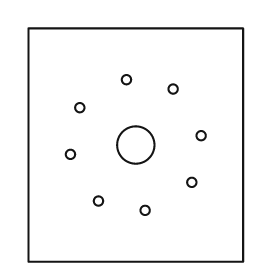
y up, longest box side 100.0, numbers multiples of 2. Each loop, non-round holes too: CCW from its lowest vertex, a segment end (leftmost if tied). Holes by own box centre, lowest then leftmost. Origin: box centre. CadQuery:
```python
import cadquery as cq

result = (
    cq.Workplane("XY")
    .moveTo(-46.0, -50.0)
    .lineTo(46.0, -50.0)
    .lineTo(46.0, 50.0)
    .lineTo(-46.0, 50.0)
    .close()
    .moveTo(4.0, -28.0)
    .circle(2.0)
    .moveTo(-16.0, -24.0)
    .circle(2.0)
    .moveTo(24.0, -16.0)
    .circle(2.0)
    .moveTo(-28.0, -4.0)
    .circle(2.0)
    .moveTo(0.0, 0.0)
    .circle(8.0)
    .moveTo(28.0, 4.0)
    .circle(2.0)
    .moveTo(-24.0, 16.0)
    .circle(2.0)
    .moveTo(16.0, 24.0)
    .circle(2.0)
    .moveTo(-4.0, 28.0)
    .circle(2.0)
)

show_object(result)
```